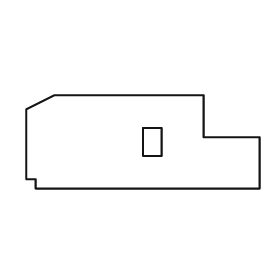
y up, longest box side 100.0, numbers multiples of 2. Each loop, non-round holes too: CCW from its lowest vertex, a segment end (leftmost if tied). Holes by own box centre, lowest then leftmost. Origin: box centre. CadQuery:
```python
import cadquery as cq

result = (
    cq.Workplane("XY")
    .moveTo(-46.0, -20.0)
    .lineTo(50.0, -20.0)
    .lineTo(50.0, 2.0)
    .lineTo(26.0, 2.0)
    .lineTo(26.0, 20.0)
    .lineTo(-38.0, 20.0)
    .lineTo(-50.0, 14.0)
    .lineTo(-50.0, -16.0)
    .lineTo(-46.0, -16.0)
    .close()
    .moveTo(0.0, -6.0)
    .lineTo(8.0, -6.0)
    .lineTo(8.0, 6.0)
    .lineTo(0.0, 6.0)
    .close()
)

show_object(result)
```